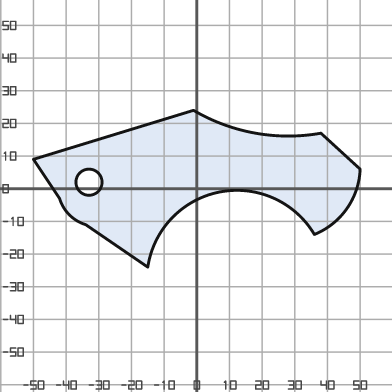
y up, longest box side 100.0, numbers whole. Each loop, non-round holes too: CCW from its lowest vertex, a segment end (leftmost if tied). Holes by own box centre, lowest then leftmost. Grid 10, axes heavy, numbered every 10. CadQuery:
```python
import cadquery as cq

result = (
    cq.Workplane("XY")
    .moveTo(-15.0, -24.0)
    .threePointArc((7.0, -1.0), (36.0, -14.0))
    .threePointArc((46.0, -6.0), (50.0, 6.0))
    .lineTo(38.0, 17.0)
    .threePointArc((18.0, 17.0), (-1.0, 24.0))
    .lineTo(-50.0, 9.0)
    .lineTo(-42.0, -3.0)
    .threePointArc((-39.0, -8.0), (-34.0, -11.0))
    .close()
    .moveTo(-33.0, 2.0)
    .circle(4.0)
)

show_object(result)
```